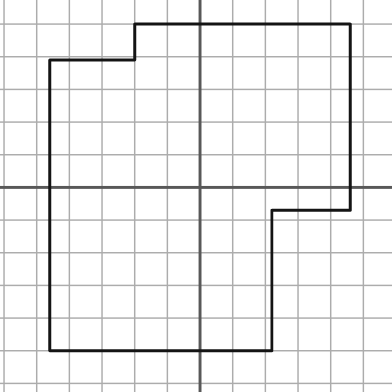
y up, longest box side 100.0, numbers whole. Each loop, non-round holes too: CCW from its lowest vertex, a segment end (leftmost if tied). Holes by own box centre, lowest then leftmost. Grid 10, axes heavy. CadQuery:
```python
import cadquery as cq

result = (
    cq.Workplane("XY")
    .moveTo(-46.0, -50.0)
    .lineTo(22.0, -50.0)
    .lineTo(22.0, -7.0)
    .lineTo(46.0, -7.0)
    .lineTo(46.0, 50.0)
    .lineTo(-20.0, 50.0)
    .lineTo(-20.0, 39.0)
    .lineTo(-46.0, 39.0)
    .close()
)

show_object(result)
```